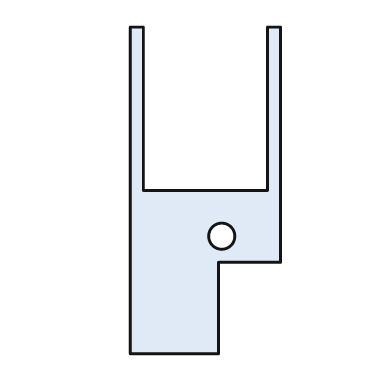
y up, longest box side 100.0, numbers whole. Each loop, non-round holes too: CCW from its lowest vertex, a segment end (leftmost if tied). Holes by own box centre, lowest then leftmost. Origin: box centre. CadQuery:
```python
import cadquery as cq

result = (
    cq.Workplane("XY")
    .moveTo(-23.0, -50.0)
    .lineTo(4.0, -50.0)
    .lineTo(4.0, -22.0)
    .lineTo(23.0, -22.0)
    .lineTo(23.0, 50.0)
    .lineTo(19.0, 50.0)
    .lineTo(19.0, 0.0)
    .lineTo(-19.0, 0.0)
    .lineTo(-19.0, 50.0)
    .lineTo(-23.0, 50.0)
    .close()
    .moveTo(5.0, -14.0)
    .circle(4.0)
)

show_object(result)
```